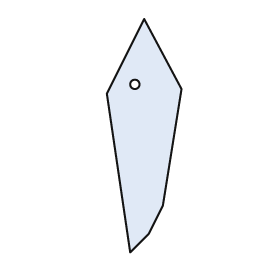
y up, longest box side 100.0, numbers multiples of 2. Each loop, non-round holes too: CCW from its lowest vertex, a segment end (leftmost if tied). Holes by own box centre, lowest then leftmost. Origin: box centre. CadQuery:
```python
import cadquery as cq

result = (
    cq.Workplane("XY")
    .moveTo(-6.0, -50.0)
    .lineTo(2.0, -42.0)
    .lineTo(8.0, -30.0)
    .lineTo(16.0, 20.0)
    .lineTo(0.0, 50.0)
    .lineTo(-16.0, 18.0)
    .close()
    .moveTo(-4.0, 22.0)
    .circle(2.0)
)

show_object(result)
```